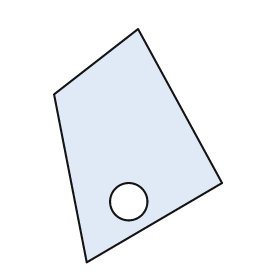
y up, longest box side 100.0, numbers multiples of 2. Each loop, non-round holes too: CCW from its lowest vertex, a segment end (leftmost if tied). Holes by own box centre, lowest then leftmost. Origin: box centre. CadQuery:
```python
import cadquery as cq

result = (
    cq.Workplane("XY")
    .moveTo(-22.0, -50.0)
    .lineTo(36.0, -16.0)
    .lineTo(0.0, 50.0)
    .lineTo(-36.0, 22.0)
    .close()
    .moveTo(-4.0, -24.0)
    .circle(8.0)
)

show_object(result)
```